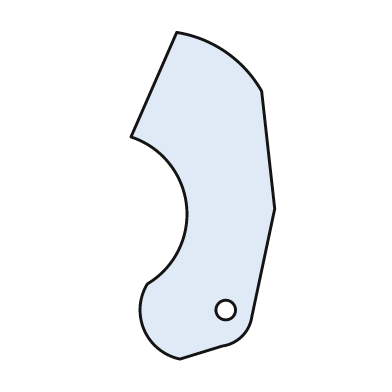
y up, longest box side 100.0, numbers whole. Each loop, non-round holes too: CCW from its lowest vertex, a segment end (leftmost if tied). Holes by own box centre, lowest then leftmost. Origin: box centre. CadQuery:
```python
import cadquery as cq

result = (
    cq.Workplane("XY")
    .moveTo(-7.0, -50.0)
    .lineTo(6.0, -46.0)
    .threePointArc((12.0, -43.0), (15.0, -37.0))
    .lineTo(22.0, -4.0)
    .lineTo(18.0, 32.0)
    .threePointArc((7.0, 44.0), (-8.0, 50.0))
    .lineTo(-22.0, 18.0)
    .threePointArc((-5.0, -3.0), (-17.0, -27.0))
    .threePointArc((-18.0, -41.0), (-7.0, -50.0))
    .close()
    .moveTo(7.0, -35.0)
    .circle(3.0)
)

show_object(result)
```